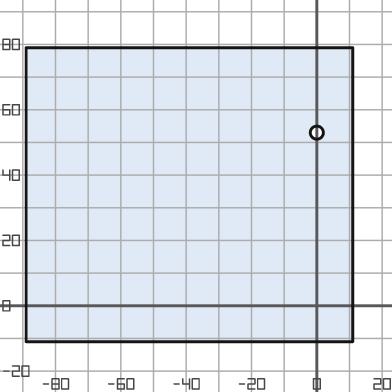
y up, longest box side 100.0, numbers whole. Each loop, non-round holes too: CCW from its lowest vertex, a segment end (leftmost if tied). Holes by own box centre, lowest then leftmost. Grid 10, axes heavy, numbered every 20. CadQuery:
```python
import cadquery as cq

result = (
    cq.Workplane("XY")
    .moveTo(-89.0, -11.0)
    .lineTo(11.0, -11.0)
    .lineTo(11.0, 79.0)
    .lineTo(-89.0, 79.0)
    .close()
    .moveTo(0.0, 53.0)
    .circle(2.0)
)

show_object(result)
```